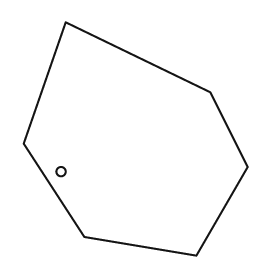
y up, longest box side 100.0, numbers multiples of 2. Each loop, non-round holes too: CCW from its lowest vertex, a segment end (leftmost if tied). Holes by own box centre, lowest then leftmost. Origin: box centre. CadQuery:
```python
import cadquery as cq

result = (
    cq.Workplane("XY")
    .moveTo(26.0, -50.0)
    .lineTo(48.0, -12.0)
    .lineTo(32.0, 20.0)
    .lineTo(-30.0, 50.0)
    .lineTo(-48.0, -2.0)
    .lineTo(-22.0, -42.0)
    .close()
    .moveTo(-32.0, -14.0)
    .circle(2.0)
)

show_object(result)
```